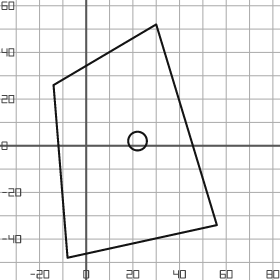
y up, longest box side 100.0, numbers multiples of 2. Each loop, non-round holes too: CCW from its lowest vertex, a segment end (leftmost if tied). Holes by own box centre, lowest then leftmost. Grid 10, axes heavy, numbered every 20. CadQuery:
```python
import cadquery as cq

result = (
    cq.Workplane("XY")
    .moveTo(-8.0, -48.0)
    .lineTo(56.0, -34.0)
    .lineTo(30.0, 52.0)
    .lineTo(-14.0, 26.0)
    .close()
    .moveTo(22.0, 2.0)
    .circle(4.0)
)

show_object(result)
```